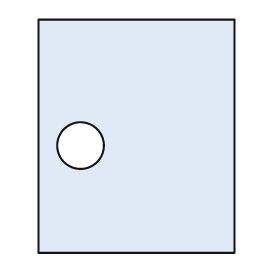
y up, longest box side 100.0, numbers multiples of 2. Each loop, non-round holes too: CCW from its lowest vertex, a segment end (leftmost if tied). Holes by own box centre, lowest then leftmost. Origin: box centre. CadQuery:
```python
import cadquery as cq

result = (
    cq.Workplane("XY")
    .moveTo(-42.0, -50.0)
    .lineTo(42.0, -50.0)
    .lineTo(42.0, 50.0)
    .lineTo(-42.0, 50.0)
    .close()
    .moveTo(-24.0, -4.0)
    .circle(10.0)
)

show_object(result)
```